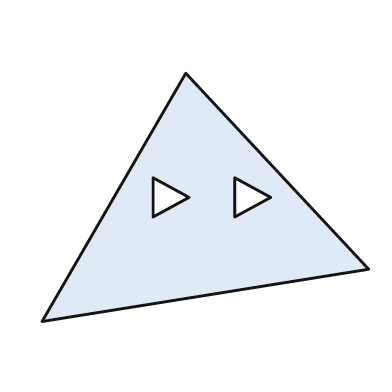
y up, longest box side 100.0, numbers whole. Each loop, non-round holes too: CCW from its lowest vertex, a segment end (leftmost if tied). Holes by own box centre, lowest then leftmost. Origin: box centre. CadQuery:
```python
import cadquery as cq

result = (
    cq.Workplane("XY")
    .moveTo(-50.0, -38.0)
    .lineTo(50.0, -22.0)
    .lineTo(-6.0, 38.0)
    .close()
    .moveTo(-16.0, -6.0)
    .lineTo(-5.0, 0.0)
    .lineTo(-16.0, 6.0)
    .close()
    .moveTo(9.0, -6.0)
    .lineTo(20.0, 0.0)
    .lineTo(9.0, 6.0)
    .close()
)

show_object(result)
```